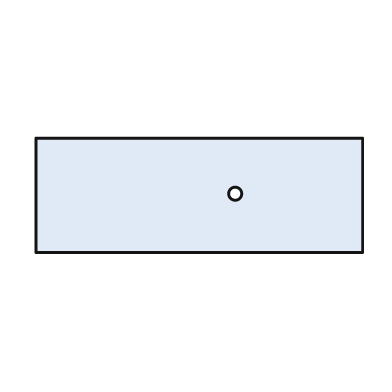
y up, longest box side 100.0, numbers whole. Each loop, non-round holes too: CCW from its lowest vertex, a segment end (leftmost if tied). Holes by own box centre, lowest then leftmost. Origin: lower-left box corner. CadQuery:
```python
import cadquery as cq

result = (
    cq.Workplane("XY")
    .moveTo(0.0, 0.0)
    .lineTo(100.0, 0.0)
    .lineTo(100.0, 35.0)
    .lineTo(0.0, 35.0)
    .close()
    .moveTo(61.0, 18.0)
    .circle(2.0)
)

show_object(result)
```